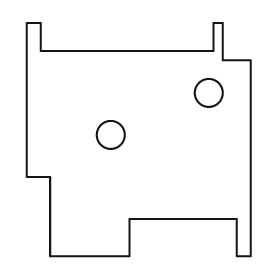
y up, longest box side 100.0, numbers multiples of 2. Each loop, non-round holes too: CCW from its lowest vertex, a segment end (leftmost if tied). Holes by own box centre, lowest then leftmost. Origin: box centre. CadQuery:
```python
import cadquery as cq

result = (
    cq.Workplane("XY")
    .moveTo(-38.0, -50.0)
    .lineTo(-4.0, -50.0)
    .lineTo(-4.0, -34.0)
    .lineTo(42.0, -34.0)
    .lineTo(42.0, -50.0)
    .lineTo(48.0, -50.0)
    .lineTo(48.0, 34.0)
    .lineTo(36.0, 34.0)
    .lineTo(36.0, 50.0)
    .lineTo(32.0, 50.0)
    .lineTo(32.0, 38.0)
    .lineTo(-42.0, 38.0)
    .lineTo(-42.0, 50.0)
    .lineTo(-48.0, 50.0)
    .lineTo(-48.0, -16.0)
    .lineTo(-38.0, -16.0)
    .close()
    .moveTo(-12.0, 2.0)
    .circle(6.0)
    .moveTo(30.0, 20.0)
    .circle(6.0)
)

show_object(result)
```